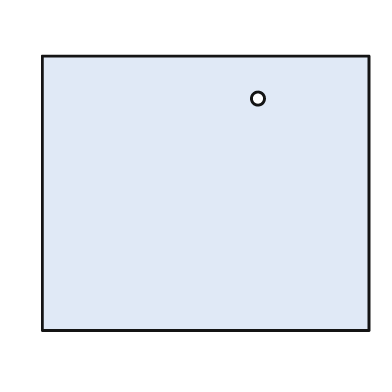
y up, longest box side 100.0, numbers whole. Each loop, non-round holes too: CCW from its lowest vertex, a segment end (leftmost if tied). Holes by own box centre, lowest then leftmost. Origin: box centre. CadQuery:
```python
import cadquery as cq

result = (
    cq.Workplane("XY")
    .moveTo(-50.0, -42.0)
    .lineTo(50.0, -42.0)
    .lineTo(50.0, 42.0)
    .lineTo(-50.0, 42.0)
    .close()
    .moveTo(16.0, 29.0)
    .circle(2.0)
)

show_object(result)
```